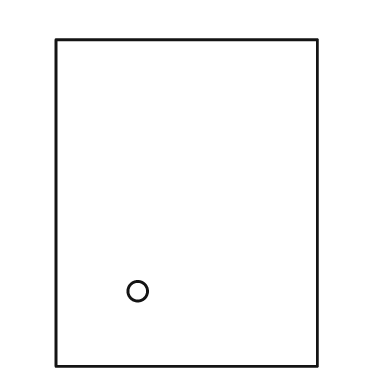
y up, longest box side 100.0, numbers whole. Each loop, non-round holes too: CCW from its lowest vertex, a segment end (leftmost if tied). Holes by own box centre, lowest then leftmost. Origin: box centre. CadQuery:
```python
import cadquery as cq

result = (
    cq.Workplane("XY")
    .moveTo(-40.0, -50.0)
    .lineTo(40.0, -50.0)
    .lineTo(40.0, 50.0)
    .lineTo(-40.0, 50.0)
    .close()
    .moveTo(-15.0, -27.0)
    .circle(3.0)
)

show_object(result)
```